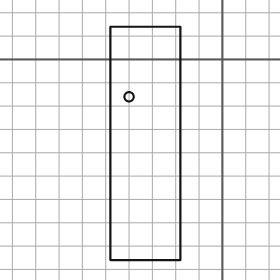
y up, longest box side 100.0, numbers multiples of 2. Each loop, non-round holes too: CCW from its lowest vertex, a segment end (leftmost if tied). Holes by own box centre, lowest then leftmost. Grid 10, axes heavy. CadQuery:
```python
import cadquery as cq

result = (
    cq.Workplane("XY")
    .moveTo(-48.0, -86.0)
    .lineTo(-18.0, -86.0)
    .lineTo(-18.0, 14.0)
    .lineTo(-48.0, 14.0)
    .close()
    .moveTo(-40.0, -16.0)
    .circle(2.0)
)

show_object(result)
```